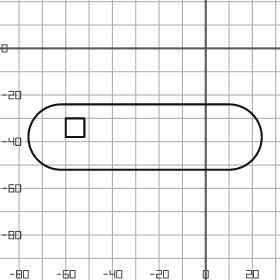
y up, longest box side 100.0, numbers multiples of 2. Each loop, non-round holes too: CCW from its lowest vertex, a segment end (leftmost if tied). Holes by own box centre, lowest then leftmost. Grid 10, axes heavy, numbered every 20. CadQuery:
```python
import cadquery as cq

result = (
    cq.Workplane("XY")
    .moveTo(-62.0, -52.0)
    .lineTo(10.0, -52.0)
    .threePointArc((24.0, -38.0), (10.0, -24.0))
    .lineTo(-62.0, -24.0)
    .threePointArc((-76.0, -38.0), (-62.0, -52.0))
    .close()
    .moveTo(-60.0, -38.0)
    .lineTo(-52.0, -38.0)
    .lineTo(-52.0, -30.0)
    .lineTo(-60.0, -30.0)
    .close()
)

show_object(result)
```